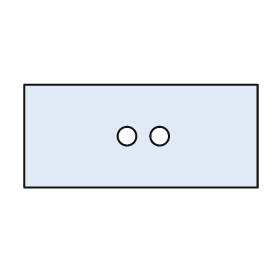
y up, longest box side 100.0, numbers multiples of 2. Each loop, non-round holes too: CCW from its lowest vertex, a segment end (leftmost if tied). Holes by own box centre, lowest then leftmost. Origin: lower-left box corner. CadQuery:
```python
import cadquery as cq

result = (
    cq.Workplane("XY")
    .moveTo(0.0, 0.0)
    .lineTo(100.0, 0.0)
    .lineTo(100.0, 44.0)
    .lineTo(0.0, 44.0)
    .close()
    .moveTo(44.0, 22.0)
    .circle(4.0)
    .moveTo(58.0, 22.0)
    .circle(4.0)
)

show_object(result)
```